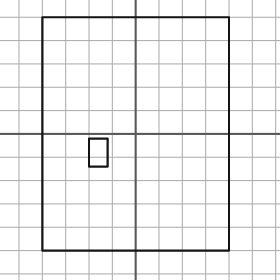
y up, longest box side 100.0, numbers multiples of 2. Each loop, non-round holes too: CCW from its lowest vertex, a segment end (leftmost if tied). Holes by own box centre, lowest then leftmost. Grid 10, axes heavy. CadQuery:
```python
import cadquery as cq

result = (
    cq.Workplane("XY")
    .moveTo(-40.0, -50.0)
    .lineTo(40.0, -50.0)
    .lineTo(40.0, 50.0)
    .lineTo(-40.0, 50.0)
    .close()
    .moveTo(-20.0, -14.0)
    .lineTo(-12.0, -14.0)
    .lineTo(-12.0, -2.0)
    .lineTo(-20.0, -2.0)
    .close()
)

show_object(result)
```